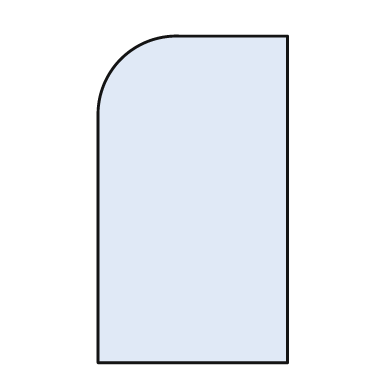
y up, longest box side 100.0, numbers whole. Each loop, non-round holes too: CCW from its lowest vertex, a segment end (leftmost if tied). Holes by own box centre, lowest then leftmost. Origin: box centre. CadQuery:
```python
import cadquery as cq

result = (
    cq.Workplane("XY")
    .moveTo(-29.0, -50.0)
    .lineTo(29.0, -50.0)
    .lineTo(29.0, 50.0)
    .lineTo(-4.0, 50.0)
    .threePointArc((-22.0, 43.0), (-29.0, 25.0))
    .close()
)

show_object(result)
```